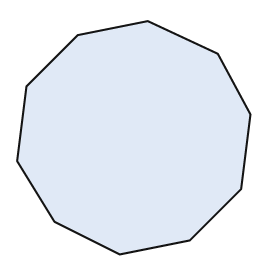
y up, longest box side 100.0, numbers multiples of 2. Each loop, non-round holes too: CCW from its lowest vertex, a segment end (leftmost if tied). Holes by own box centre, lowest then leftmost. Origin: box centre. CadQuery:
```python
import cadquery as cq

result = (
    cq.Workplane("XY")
    .moveTo(-6.0, -50.0)
    .lineTo(24.0, -44.0)
    .lineTo(46.0, -22.0)
    .lineTo(50.0, 10.0)
    .lineTo(36.0, 36.0)
    .lineTo(6.0, 50.0)
    .lineTo(-24.0, 44.0)
    .lineTo(-46.0, 22.0)
    .lineTo(-50.0, -10.0)
    .lineTo(-34.0, -36.0)
    .close()
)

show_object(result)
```